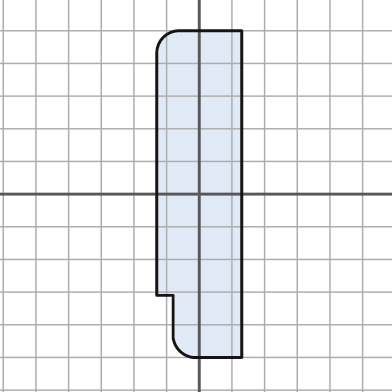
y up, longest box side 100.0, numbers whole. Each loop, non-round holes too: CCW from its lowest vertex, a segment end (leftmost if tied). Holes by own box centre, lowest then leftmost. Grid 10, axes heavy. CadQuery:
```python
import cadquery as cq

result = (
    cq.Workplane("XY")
    .moveTo(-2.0, -50.0)
    .lineTo(13.0, -50.0)
    .lineTo(13.0, 50.0)
    .lineTo(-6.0, 50.0)
    .threePointArc((-11.0, 48.0), (-13.0, 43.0))
    .lineTo(-13.0, -31.0)
    .lineTo(-8.0, -31.0)
    .lineTo(-8.0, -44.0)
    .threePointArc((-6.0, -48.0), (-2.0, -50.0))
    .close()
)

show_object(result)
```